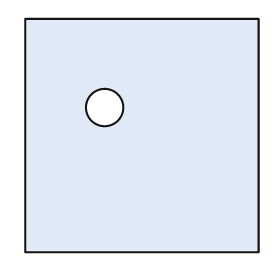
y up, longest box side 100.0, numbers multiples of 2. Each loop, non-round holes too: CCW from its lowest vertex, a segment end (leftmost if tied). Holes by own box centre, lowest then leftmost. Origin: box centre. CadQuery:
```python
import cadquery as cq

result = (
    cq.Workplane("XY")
    .moveTo(-50.0, -50.0)
    .lineTo(50.0, -50.0)
    .lineTo(50.0, 50.0)
    .lineTo(-50.0, 50.0)
    .close()
    .moveTo(-16.0, 12.0)
    .circle(8.0)
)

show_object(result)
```